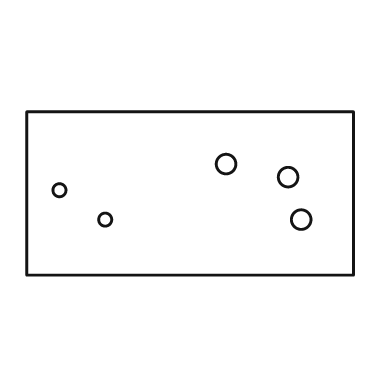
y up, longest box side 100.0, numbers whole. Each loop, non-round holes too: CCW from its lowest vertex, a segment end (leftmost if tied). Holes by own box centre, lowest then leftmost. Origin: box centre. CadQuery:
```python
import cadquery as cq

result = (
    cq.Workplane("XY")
    .moveTo(-50.0, -25.0)
    .lineTo(50.0, -25.0)
    .lineTo(50.0, 25.0)
    .lineTo(-50.0, 25.0)
    .close()
    .moveTo(-26.0, -8.0)
    .circle(2.0)
    .moveTo(34.0, -8.0)
    .circle(3.0)
    .moveTo(-40.0, 1.0)
    .circle(2.0)
    .moveTo(30.0, 5.0)
    .circle(3.0)
    .moveTo(11.0, 9.0)
    .circle(3.0)
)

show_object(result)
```